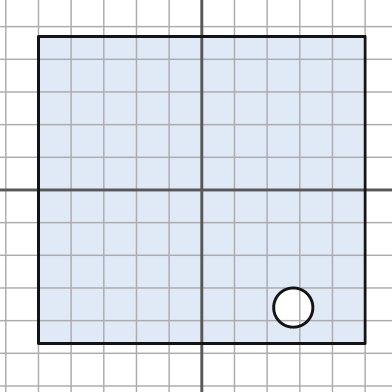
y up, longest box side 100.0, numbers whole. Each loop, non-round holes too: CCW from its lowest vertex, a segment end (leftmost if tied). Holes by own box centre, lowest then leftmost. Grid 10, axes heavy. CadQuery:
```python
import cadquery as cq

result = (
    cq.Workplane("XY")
    .moveTo(-50.0, -47.0)
    .lineTo(50.0, -47.0)
    .lineTo(50.0, 47.0)
    .lineTo(-50.0, 47.0)
    .close()
    .moveTo(28.0, -36.0)
    .circle(6.0)
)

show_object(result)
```